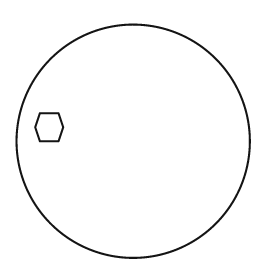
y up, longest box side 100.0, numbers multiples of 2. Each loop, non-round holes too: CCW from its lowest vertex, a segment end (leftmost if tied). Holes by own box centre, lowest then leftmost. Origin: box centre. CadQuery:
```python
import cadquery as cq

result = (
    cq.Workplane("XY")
    .moveTo(0.0, 0.0)
    .circle(50.0)
    .moveTo(-40.0, 0.0)
    .lineTo(-32.0, 0.0)
    .lineTo(-30.0, 6.0)
    .lineTo(-32.0, 12.0)
    .lineTo(-40.0, 12.0)
    .lineTo(-42.0, 6.0)
    .close()
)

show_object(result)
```